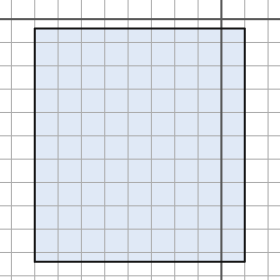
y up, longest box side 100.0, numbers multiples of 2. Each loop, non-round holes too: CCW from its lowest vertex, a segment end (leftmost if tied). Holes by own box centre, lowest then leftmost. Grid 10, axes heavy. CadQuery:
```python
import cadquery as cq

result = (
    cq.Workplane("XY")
    .moveTo(-80.0, -104.0)
    .lineTo(10.0, -104.0)
    .lineTo(10.0, -4.0)
    .lineTo(-80.0, -4.0)
    .close()
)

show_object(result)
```